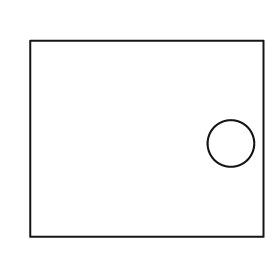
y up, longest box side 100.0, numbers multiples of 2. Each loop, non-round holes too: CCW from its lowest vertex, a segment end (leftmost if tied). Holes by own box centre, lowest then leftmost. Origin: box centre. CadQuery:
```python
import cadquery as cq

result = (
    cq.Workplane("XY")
    .moveTo(-50.0, -42.0)
    .lineTo(50.0, -42.0)
    .lineTo(50.0, 42.0)
    .lineTo(-50.0, 42.0)
    .close()
    .moveTo(36.0, -2.0)
    .circle(10.0)
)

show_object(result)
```